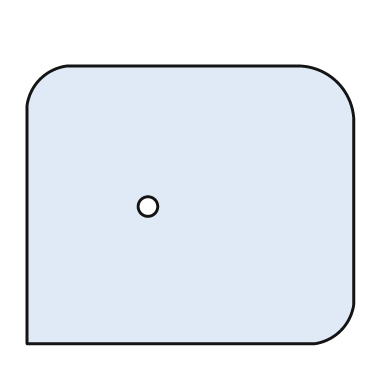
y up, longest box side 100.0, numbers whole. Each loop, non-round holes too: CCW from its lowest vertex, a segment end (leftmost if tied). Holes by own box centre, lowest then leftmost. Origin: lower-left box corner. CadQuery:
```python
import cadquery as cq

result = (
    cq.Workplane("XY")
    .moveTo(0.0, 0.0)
    .lineTo(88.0, 0.0)
    .threePointArc((96.0, 4.0), (100.0, 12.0))
    .lineTo(100.0, 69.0)
    .threePointArc((95.0, 80.0), (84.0, 85.0))
    .lineTo(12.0, 85.0)
    .threePointArc((4.0, 81.0), (0.0, 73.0))
    .close()
    .moveTo(37.0, 42.0)
    .circle(3.0)
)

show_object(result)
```